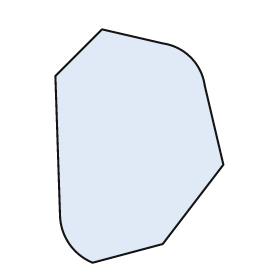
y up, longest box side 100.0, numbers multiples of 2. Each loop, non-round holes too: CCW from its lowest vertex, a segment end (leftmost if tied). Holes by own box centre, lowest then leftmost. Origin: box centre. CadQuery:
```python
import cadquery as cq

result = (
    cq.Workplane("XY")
    .moveTo(-20.0, -50.0)
    .lineTo(10.0, -42.0)
    .lineTo(36.0, -8.0)
    .lineTo(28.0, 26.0)
    .threePointArc((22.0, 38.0), (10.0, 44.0))
    .lineTo(-16.0, 50.0)
    .lineTo(-36.0, 30.0)
    .lineTo(-34.0, -30.0)
    .threePointArc((-30.0, -42.0), (-20.0, -50.0))
    .close()
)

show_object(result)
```